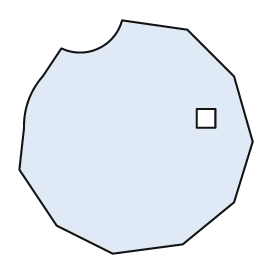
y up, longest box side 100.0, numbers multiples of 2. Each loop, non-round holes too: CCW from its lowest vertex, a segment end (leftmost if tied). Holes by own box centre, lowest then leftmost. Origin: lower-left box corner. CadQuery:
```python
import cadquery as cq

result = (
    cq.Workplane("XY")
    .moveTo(40.0, 0.0)
    .lineTo(70.0, 4.0)
    .lineTo(92.0, 22.0)
    .lineTo(100.0, 48.0)
    .lineTo(92.0, 76.0)
    .lineTo(72.0, 96.0)
    .lineTo(44.0, 100.0)
    .threePointArc((34.0, 88.0), (18.0, 88.0))
    .lineTo(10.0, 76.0)
    .threePointArc((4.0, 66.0), (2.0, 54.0))
    .lineTo(0.0, 36.0)
    .lineTo(16.0, 12.0)
    .close()
    .moveTo(76.0, 54.0)
    .lineTo(84.0, 54.0)
    .lineTo(84.0, 62.0)
    .lineTo(76.0, 62.0)
    .close()
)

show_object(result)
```